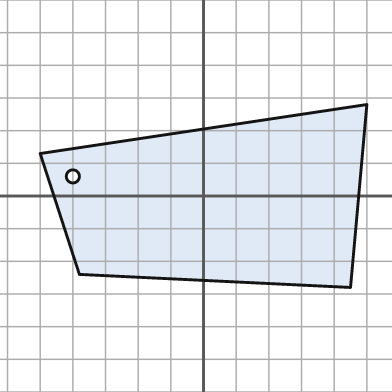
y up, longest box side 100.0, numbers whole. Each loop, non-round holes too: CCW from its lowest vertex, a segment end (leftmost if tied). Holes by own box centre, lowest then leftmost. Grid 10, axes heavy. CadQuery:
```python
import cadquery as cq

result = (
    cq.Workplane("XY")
    .moveTo(45.0, -28.0)
    .lineTo(50.0, 28.0)
    .lineTo(-50.0, 13.0)
    .lineTo(-38.0, -24.0)
    .close()
    .moveTo(-40.0, 6.0)
    .circle(2.0)
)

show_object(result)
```